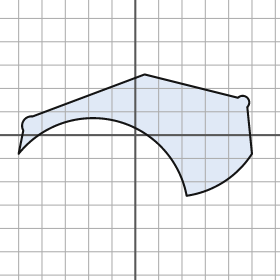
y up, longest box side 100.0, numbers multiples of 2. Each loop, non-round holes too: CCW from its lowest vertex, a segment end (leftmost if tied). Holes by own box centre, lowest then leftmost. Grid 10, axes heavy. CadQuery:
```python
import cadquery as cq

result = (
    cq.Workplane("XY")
    .moveTo(22.0, -26.0)
    .threePointArc((38.0, -20.0), (50.0, -8.0))
    .lineTo(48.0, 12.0)
    .threePointArc((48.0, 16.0), (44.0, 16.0))
    .lineTo(4.0, 26.0)
    .lineTo(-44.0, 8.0)
    .threePointArc((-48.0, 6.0), (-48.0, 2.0))
    .lineTo(-50.0, -8.0)
    .threePointArc((-8.0, 6.0), (22.0, -26.0))
    .close()
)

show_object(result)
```